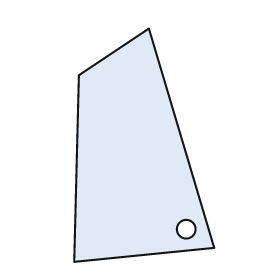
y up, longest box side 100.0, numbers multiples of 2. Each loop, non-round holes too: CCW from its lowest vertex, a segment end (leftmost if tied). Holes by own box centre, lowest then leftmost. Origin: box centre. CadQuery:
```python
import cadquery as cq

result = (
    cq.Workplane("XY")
    .moveTo(-30.0, -50.0)
    .lineTo(30.0, -44.0)
    .lineTo(2.0, 50.0)
    .lineTo(-28.0, 30.0)
    .close()
    .moveTo(18.0, -36.0)
    .circle(4.0)
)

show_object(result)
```